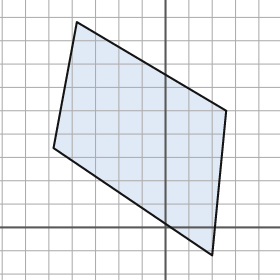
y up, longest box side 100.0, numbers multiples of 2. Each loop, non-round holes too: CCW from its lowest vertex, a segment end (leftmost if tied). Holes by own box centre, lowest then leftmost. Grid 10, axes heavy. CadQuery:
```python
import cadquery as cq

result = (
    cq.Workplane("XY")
    .moveTo(20.0, -12.0)
    .lineTo(26.0, 50.0)
    .lineTo(-38.0, 88.0)
    .lineTo(-48.0, 34.0)
    .close()
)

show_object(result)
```